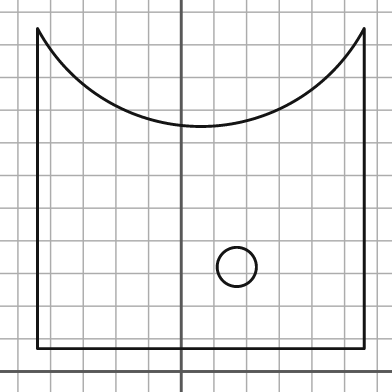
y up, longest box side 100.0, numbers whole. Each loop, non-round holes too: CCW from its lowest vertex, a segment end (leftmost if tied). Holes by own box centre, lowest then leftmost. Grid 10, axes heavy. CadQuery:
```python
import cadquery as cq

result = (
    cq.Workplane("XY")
    .moveTo(-44.0, 7.0)
    .lineTo(56.0, 7.0)
    .lineTo(56.0, 105.0)
    .threePointArc((6.0, 75.0), (-44.0, 105.0))
    .close()
    .moveTo(17.0, 32.0)
    .circle(6.0)
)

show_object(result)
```